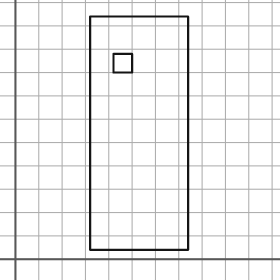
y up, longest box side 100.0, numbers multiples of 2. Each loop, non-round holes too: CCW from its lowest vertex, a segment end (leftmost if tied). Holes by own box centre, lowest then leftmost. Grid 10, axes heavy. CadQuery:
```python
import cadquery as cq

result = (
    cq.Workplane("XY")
    .moveTo(32.0, 4.0)
    .lineTo(74.0, 4.0)
    .lineTo(74.0, 104.0)
    .lineTo(32.0, 104.0)
    .close()
    .moveTo(42.0, 80.0)
    .lineTo(50.0, 80.0)
    .lineTo(50.0, 88.0)
    .lineTo(42.0, 88.0)
    .close()
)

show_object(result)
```